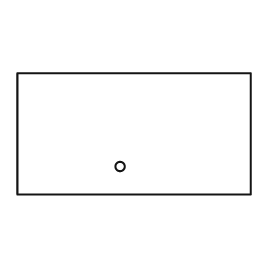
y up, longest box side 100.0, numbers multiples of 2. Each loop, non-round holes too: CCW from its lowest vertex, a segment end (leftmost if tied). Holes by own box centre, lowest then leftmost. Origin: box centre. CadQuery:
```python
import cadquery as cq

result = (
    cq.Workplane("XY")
    .moveTo(-50.0, -26.0)
    .lineTo(50.0, -26.0)
    .lineTo(50.0, 26.0)
    .lineTo(-50.0, 26.0)
    .close()
    .moveTo(-6.0, -14.0)
    .circle(2.0)
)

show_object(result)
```